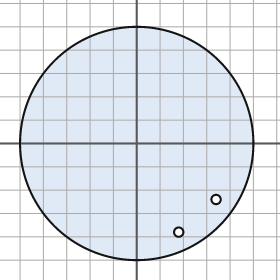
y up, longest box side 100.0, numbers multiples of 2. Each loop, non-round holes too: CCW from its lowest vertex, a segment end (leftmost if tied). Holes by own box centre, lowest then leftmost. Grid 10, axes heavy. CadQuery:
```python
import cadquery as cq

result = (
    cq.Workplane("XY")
    .moveTo(0.0, 0.0)
    .circle(50.0)
    .moveTo(18.0, -38.0)
    .circle(2.0)
    .moveTo(34.0, -24.0)
    .circle(2.0)
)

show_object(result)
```